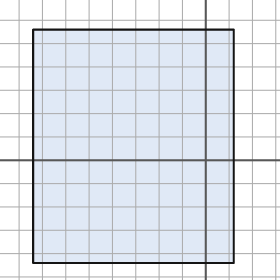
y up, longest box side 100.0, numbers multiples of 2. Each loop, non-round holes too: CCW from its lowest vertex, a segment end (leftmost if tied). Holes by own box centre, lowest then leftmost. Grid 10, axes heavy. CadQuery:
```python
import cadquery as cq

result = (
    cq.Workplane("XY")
    .moveTo(-74.0, -44.0)
    .lineTo(12.0, -44.0)
    .lineTo(12.0, 56.0)
    .lineTo(-74.0, 56.0)
    .close()
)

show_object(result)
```